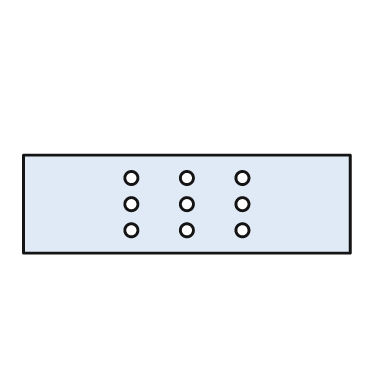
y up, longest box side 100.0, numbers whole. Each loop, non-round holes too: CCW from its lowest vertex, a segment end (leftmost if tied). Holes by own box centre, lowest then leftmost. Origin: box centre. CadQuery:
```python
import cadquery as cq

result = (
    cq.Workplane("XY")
    .moveTo(-50.0, -15.0)
    .lineTo(50.0, -15.0)
    .lineTo(50.0, 15.0)
    .lineTo(-50.0, 15.0)
    .close()
    .moveTo(-17.0, -8.0)
    .circle(2.0)
    .moveTo(0.0, -8.0)
    .circle(2.0)
    .moveTo(17.0, -8.0)
    .circle(2.0)
    .moveTo(-17.0, 0.0)
    .circle(2.0)
    .moveTo(0.0, 0.0)
    .circle(2.0)
    .moveTo(17.0, 0.0)
    .circle(2.0)
    .moveTo(-17.0, 8.0)
    .circle(2.0)
    .moveTo(0.0, 8.0)
    .circle(2.0)
    .moveTo(17.0, 8.0)
    .circle(2.0)
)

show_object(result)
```